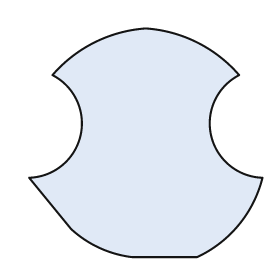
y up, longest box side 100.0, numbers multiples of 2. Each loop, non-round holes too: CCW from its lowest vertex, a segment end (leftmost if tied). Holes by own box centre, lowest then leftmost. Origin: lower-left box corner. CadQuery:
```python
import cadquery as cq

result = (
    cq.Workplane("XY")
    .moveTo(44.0, 0.0)
    .lineTo(72.0, 0.0)
    .threePointArc((90.0, 14.0), (100.0, 34.0))
    .threePointArc((78.0, 52.0), (90.0, 78.0))
    .threePointArc((72.0, 92.0), (50.0, 98.0))
    .threePointArc((28.0, 92.0), (10.0, 78.0))
    .threePointArc((22.0, 52.0), (0.0, 34.0))
    .lineTo(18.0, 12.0)
    .threePointArc((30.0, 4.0), (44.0, 0.0))
    .close()
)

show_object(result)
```